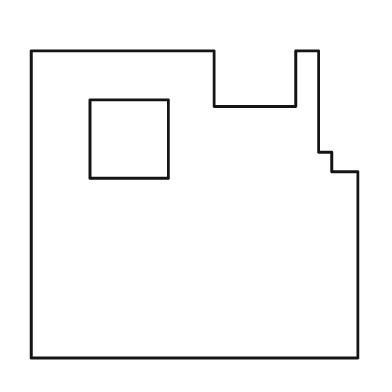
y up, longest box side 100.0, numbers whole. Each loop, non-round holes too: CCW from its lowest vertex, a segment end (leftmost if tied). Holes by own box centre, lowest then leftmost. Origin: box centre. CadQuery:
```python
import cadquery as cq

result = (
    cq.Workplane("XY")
    .moveTo(-50.0, -47.0)
    .lineTo(50.0, -47.0)
    .lineTo(50.0, 10.0)
    .lineTo(42.0, 10.0)
    .lineTo(42.0, 16.0)
    .lineTo(38.0, 16.0)
    .lineTo(38.0, 47.0)
    .lineTo(31.0, 47.0)
    .lineTo(31.0, 30.0)
    .lineTo(6.0, 30.0)
    .lineTo(6.0, 47.0)
    .lineTo(-50.0, 47.0)
    .close()
    .moveTo(-32.0, 8.0)
    .lineTo(-8.0, 8.0)
    .lineTo(-8.0, 32.0)
    .lineTo(-32.0, 32.0)
    .close()
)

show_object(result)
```